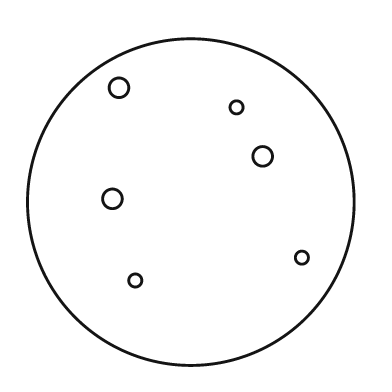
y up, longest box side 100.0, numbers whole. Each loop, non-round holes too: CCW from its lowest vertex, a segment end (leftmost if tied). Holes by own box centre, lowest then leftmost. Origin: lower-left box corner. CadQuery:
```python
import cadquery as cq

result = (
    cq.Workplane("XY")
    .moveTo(50.0, 50.0)
    .circle(50.0)
    .moveTo(33.0, 26.0)
    .circle(2.0)
    .moveTo(84.0, 33.0)
    .circle(2.0)
    .moveTo(26.0, 51.0)
    .circle(3.0)
    .moveTo(72.0, 64.0)
    .circle(3.0)
    .moveTo(64.0, 79.0)
    .circle(2.0)
    .moveTo(28.0, 85.0)
    .circle(3.0)
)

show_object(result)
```